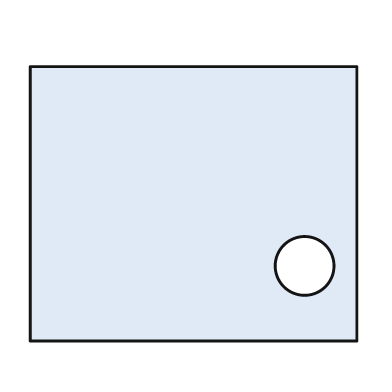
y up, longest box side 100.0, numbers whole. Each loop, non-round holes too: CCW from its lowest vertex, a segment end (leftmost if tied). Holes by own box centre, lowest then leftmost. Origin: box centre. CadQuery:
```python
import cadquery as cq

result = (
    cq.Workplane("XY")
    .moveTo(-50.0, -42.0)
    .lineTo(50.0, -42.0)
    .lineTo(50.0, 42.0)
    .lineTo(-50.0, 42.0)
    .close()
    .moveTo(34.0, -19.0)
    .circle(9.0)
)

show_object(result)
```